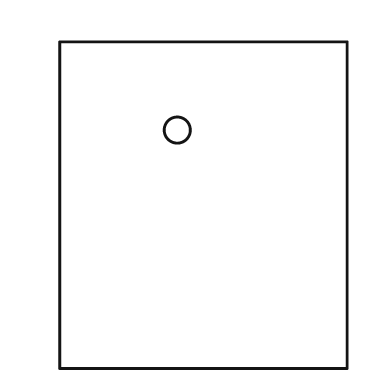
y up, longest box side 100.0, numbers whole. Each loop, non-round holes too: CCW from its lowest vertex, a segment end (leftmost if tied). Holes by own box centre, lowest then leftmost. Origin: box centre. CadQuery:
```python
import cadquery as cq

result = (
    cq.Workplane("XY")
    .moveTo(-44.0, -50.0)
    .lineTo(44.0, -50.0)
    .lineTo(44.0, 50.0)
    .lineTo(-44.0, 50.0)
    .close()
    .moveTo(-8.0, 23.0)
    .circle(4.0)
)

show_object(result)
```